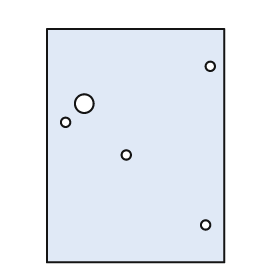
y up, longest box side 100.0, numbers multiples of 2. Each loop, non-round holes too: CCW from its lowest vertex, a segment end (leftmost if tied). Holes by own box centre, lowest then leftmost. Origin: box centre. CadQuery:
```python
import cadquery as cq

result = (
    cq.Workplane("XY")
    .moveTo(-38.0, -50.0)
    .lineTo(38.0, -50.0)
    .lineTo(38.0, 50.0)
    .lineTo(-38.0, 50.0)
    .close()
    .moveTo(30.0, -34.0)
    .circle(2.0)
    .moveTo(-4.0, -4.0)
    .circle(2.0)
    .moveTo(-30.0, 10.0)
    .circle(2.0)
    .moveTo(-22.0, 18.0)
    .circle(4.0)
    .moveTo(32.0, 34.0)
    .circle(2.0)
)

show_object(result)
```